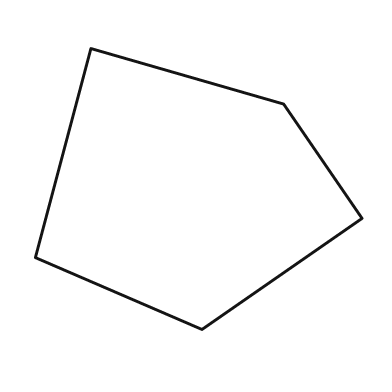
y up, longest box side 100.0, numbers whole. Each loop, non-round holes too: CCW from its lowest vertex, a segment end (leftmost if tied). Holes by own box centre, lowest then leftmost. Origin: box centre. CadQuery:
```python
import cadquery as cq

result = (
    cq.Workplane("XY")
    .moveTo(1.0, -43.0)
    .lineTo(50.0, -9.0)
    .lineTo(26.0, 26.0)
    .lineTo(-33.0, 43.0)
    .lineTo(-50.0, -21.0)
    .close()
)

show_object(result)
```